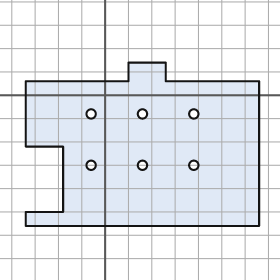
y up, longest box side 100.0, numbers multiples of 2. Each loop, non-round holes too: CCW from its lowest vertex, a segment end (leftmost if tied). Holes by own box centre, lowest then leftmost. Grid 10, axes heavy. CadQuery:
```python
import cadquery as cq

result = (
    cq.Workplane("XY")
    .moveTo(-34.0, -56.0)
    .lineTo(66.0, -56.0)
    .lineTo(66.0, 6.0)
    .lineTo(26.0, 6.0)
    .lineTo(26.0, 14.0)
    .lineTo(10.0, 14.0)
    .lineTo(10.0, 6.0)
    .lineTo(-34.0, 6.0)
    .lineTo(-34.0, -22.0)
    .lineTo(-18.0, -22.0)
    .lineTo(-18.0, -50.0)
    .lineTo(-34.0, -50.0)
    .close()
    .moveTo(-6.0, -30.0)
    .circle(2.0)
    .moveTo(16.0, -30.0)
    .circle(2.0)
    .moveTo(38.0, -30.0)
    .circle(2.0)
    .moveTo(-6.0, -8.0)
    .circle(2.0)
    .moveTo(16.0, -8.0)
    .circle(2.0)
    .moveTo(38.0, -8.0)
    .circle(2.0)
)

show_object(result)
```